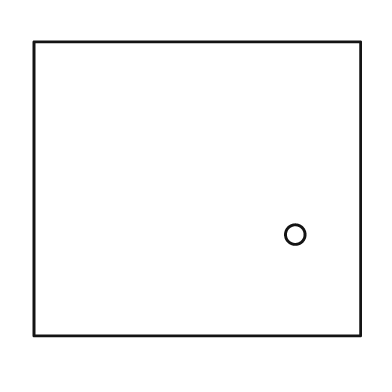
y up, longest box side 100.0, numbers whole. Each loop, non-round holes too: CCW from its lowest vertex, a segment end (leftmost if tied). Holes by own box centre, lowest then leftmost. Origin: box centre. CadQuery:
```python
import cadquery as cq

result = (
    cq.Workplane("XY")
    .moveTo(-50.0, -45.0)
    .lineTo(50.0, -45.0)
    .lineTo(50.0, 45.0)
    .lineTo(-50.0, 45.0)
    .close()
    .moveTo(30.0, -14.0)
    .circle(3.0)
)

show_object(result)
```